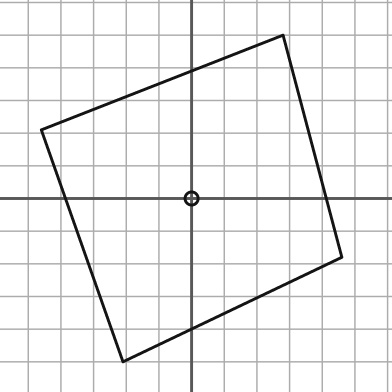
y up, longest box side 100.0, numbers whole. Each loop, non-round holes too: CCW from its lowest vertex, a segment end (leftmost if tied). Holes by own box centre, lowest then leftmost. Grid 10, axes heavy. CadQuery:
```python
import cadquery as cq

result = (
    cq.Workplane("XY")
    .moveTo(-21.0, -50.0)
    .lineTo(46.0, -18.0)
    .lineTo(28.0, 50.0)
    .lineTo(-46.0, 21.0)
    .close()
    .moveTo(0.0, 0.0)
    .circle(2.0)
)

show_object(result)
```